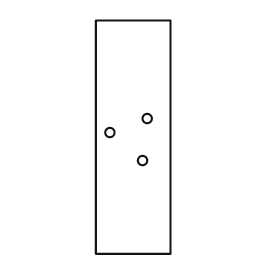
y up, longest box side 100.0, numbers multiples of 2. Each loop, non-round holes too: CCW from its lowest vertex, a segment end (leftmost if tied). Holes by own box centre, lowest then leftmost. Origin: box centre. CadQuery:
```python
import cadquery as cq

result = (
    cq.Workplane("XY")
    .moveTo(-16.0, -50.0)
    .lineTo(16.0, -50.0)
    .lineTo(16.0, 50.0)
    .lineTo(-16.0, 50.0)
    .close()
    .moveTo(4.0, -10.0)
    .circle(2.0)
    .moveTo(-10.0, 2.0)
    .circle(2.0)
    .moveTo(6.0, 8.0)
    .circle(2.0)
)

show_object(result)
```